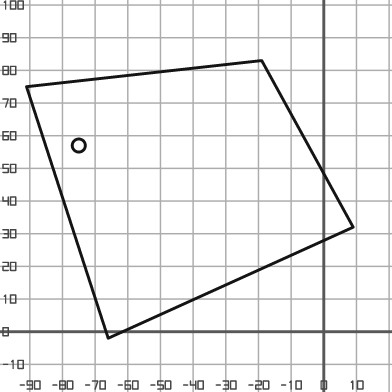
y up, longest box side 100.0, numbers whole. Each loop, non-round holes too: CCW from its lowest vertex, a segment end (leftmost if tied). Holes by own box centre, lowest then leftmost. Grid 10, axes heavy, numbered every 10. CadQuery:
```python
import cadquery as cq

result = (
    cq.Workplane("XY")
    .moveTo(-66.0, -2.0)
    .lineTo(9.0, 32.0)
    .lineTo(-19.0, 83.0)
    .lineTo(-91.0, 75.0)
    .close()
    .moveTo(-75.0, 57.0)
    .circle(2.0)
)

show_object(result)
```